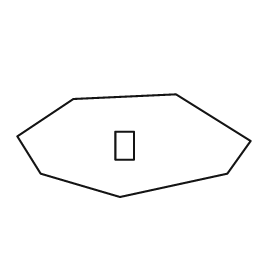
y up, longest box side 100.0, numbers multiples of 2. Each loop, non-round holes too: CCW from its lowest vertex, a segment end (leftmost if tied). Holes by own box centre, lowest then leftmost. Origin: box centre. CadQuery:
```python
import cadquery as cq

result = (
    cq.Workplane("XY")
    .moveTo(-6.0, -22.0)
    .lineTo(40.0, -12.0)
    .lineTo(50.0, 2.0)
    .lineTo(18.0, 22.0)
    .lineTo(-26.0, 20.0)
    .lineTo(-50.0, 4.0)
    .lineTo(-40.0, -12.0)
    .close()
    .moveTo(-8.0, -6.0)
    .lineTo(0.0, -6.0)
    .lineTo(0.0, 6.0)
    .lineTo(-8.0, 6.0)
    .close()
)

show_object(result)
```